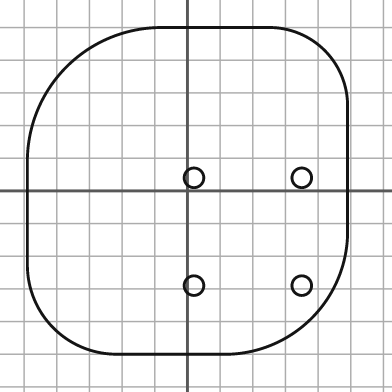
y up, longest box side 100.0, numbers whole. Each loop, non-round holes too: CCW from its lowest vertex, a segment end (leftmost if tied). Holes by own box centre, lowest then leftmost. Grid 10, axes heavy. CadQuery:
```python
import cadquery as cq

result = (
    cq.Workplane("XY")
    .moveTo(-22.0, -50.0)
    .lineTo(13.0, -50.0)
    .threePointArc((38.0, -39.0), (49.0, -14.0))
    .lineTo(49.0, 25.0)
    .threePointArc((42.0, 43.0), (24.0, 50.0))
    .lineTo(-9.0, 50.0)
    .threePointArc((-37.0, 38.0), (-49.0, 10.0))
    .lineTo(-49.0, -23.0)
    .threePointArc((-41.0, -42.0), (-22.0, -50.0))
    .close()
    .moveTo(2.0, -29.0)
    .circle(3.0)
    .moveTo(35.0, -29.0)
    .circle(3.0)
    .moveTo(2.0, 4.0)
    .circle(3.0)
    .moveTo(35.0, 4.0)
    .circle(3.0)
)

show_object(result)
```